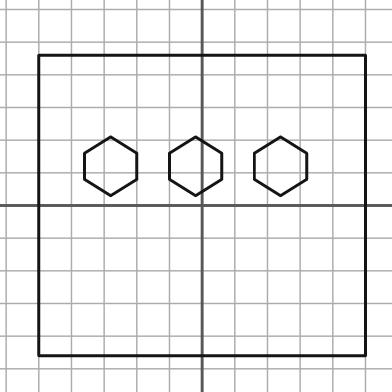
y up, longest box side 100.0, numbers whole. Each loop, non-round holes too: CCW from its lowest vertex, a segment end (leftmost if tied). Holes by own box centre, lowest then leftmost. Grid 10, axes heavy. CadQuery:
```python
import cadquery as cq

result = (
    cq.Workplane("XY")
    .moveTo(-50.0, -46.0)
    .lineTo(50.0, -46.0)
    .lineTo(50.0, 46.0)
    .lineTo(-50.0, 46.0)
    .close()
    .moveTo(-28.0, 3.0)
    .lineTo(-20.0, 8.0)
    .lineTo(-20.0, 16.0)
    .lineTo(-28.0, 21.0)
    .lineTo(-36.0, 16.0)
    .lineTo(-36.0, 8.0)
    .close()
    .moveTo(-2.0, 3.0)
    .lineTo(6.0, 8.0)
    .lineTo(6.0, 16.0)
    .lineTo(-2.0, 21.0)
    .lineTo(-10.0, 16.0)
    .lineTo(-10.0, 8.0)
    .close()
    .moveTo(24.0, 3.0)
    .lineTo(32.0, 8.0)
    .lineTo(32.0, 16.0)
    .lineTo(24.0, 21.0)
    .lineTo(16.0, 16.0)
    .lineTo(16.0, 8.0)
    .close()
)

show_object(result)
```